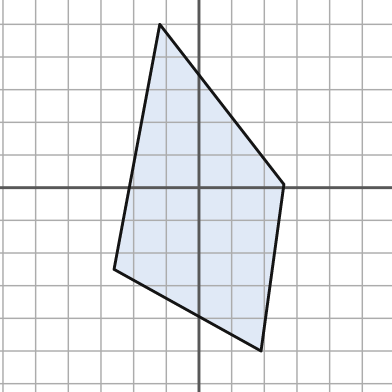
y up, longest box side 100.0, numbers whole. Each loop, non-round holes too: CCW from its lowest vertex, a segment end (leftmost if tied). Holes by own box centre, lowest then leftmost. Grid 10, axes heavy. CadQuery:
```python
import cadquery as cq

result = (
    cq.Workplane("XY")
    .moveTo(19.0, -50.0)
    .lineTo(26.0, 1.0)
    .lineTo(-12.0, 50.0)
    .lineTo(-26.0, -25.0)
    .close()
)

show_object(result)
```